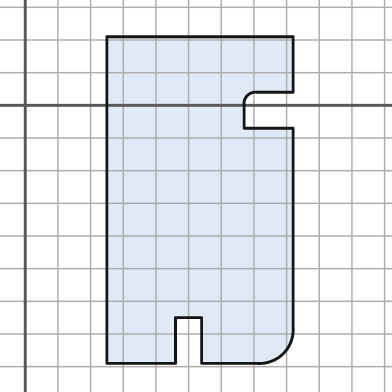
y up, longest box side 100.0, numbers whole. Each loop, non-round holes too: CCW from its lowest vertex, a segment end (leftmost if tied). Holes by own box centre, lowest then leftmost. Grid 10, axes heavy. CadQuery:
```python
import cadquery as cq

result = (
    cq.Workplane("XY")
    .moveTo(25.0, -79.0)
    .lineTo(46.0, -79.0)
    .lineTo(46.0, -65.0)
    .lineTo(54.0, -65.0)
    .lineTo(54.0, -79.0)
    .lineTo(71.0, -79.0)
    .threePointArc((79.0, -76.0), (82.0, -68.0))
    .lineTo(82.0, -7.0)
    .lineTo(67.0, -7.0)
    .lineTo(67.0, 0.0)
    .threePointArc((68.0, 3.0), (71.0, 4.0))
    .lineTo(82.0, 4.0)
    .lineTo(82.0, 21.0)
    .lineTo(25.0, 21.0)
    .close()
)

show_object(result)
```